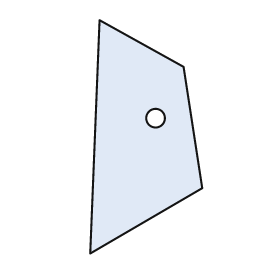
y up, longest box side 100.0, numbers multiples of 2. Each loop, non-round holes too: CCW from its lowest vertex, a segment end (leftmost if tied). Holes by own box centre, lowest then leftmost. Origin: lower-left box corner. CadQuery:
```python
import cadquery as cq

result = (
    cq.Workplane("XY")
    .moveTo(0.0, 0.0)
    .lineTo(48.0, 28.0)
    .lineTo(40.0, 80.0)
    .lineTo(4.0, 100.0)
    .close()
    .moveTo(28.0, 58.0)
    .circle(4.0)
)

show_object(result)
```